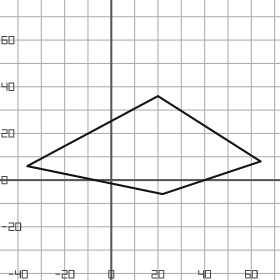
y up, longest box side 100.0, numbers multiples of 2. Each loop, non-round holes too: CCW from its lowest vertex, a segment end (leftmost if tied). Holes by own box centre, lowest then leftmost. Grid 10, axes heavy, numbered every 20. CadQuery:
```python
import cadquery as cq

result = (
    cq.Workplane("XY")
    .moveTo(22.0, -6.0)
    .lineTo(64.0, 8.0)
    .lineTo(20.0, 36.0)
    .lineTo(-36.0, 6.0)
    .close()
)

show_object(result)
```